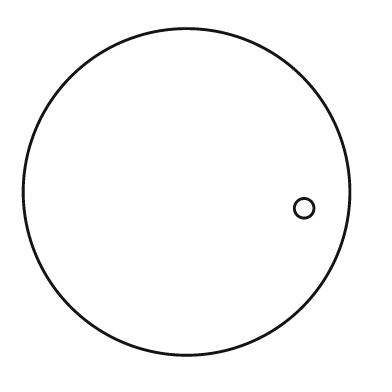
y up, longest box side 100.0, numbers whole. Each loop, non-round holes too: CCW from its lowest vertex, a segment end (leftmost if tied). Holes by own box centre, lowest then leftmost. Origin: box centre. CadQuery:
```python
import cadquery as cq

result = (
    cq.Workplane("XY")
    .moveTo(0.0, 0.0)
    .circle(50.0)
    .moveTo(36.0, -5.0)
    .circle(3.0)
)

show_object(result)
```